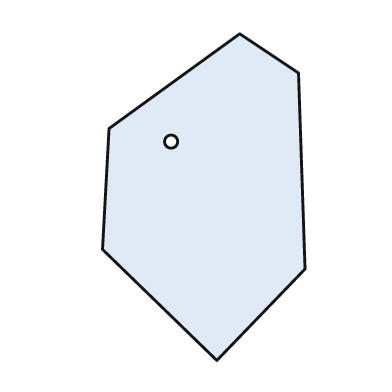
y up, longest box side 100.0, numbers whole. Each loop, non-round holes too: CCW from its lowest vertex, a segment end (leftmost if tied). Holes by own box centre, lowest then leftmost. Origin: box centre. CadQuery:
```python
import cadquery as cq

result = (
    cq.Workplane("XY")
    .moveTo(4.0, -50.0)
    .lineTo(31.0, -22.0)
    .lineTo(29.0, 38.0)
    .lineTo(11.0, 50.0)
    .lineTo(-29.0, 21.0)
    .lineTo(-31.0, -16.0)
    .close()
    .moveTo(-10.0, 17.0)
    .circle(2.0)
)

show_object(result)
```